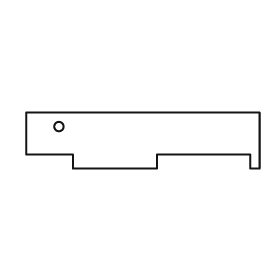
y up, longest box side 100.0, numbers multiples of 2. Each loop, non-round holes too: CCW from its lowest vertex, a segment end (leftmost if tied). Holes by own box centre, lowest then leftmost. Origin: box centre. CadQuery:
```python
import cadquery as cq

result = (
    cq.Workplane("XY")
    .moveTo(-30.0, -12.0)
    .lineTo(6.0, -12.0)
    .lineTo(6.0, -6.0)
    .lineTo(46.0, -6.0)
    .lineTo(46.0, -12.0)
    .lineTo(50.0, -12.0)
    .lineTo(50.0, 12.0)
    .lineTo(-50.0, 12.0)
    .lineTo(-50.0, -6.0)
    .lineTo(-30.0, -6.0)
    .close()
    .moveTo(-36.0, 6.0)
    .circle(2.0)
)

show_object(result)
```